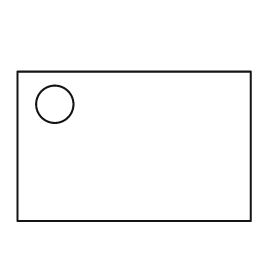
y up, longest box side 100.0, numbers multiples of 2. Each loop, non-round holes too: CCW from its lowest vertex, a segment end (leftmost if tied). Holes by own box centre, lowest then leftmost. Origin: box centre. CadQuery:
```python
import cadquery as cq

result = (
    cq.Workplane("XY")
    .moveTo(-50.0, -32.0)
    .lineTo(50.0, -32.0)
    .lineTo(50.0, 32.0)
    .lineTo(-50.0, 32.0)
    .close()
    .moveTo(-34.0, 18.0)
    .circle(8.0)
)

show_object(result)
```